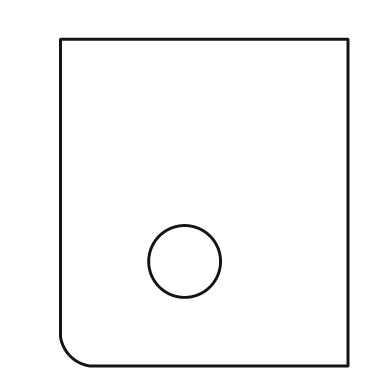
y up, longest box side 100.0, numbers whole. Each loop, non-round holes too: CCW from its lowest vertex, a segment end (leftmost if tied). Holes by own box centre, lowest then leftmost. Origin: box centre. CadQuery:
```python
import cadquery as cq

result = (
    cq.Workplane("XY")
    .moveTo(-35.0, -50.0)
    .lineTo(44.0, -50.0)
    .lineTo(44.0, 50.0)
    .lineTo(-44.0, 50.0)
    .lineTo(-44.0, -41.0)
    .threePointArc((-41.0, -47.0), (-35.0, -50.0))
    .close()
    .moveTo(-6.0, -18.0)
    .circle(11.0)
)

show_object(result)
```